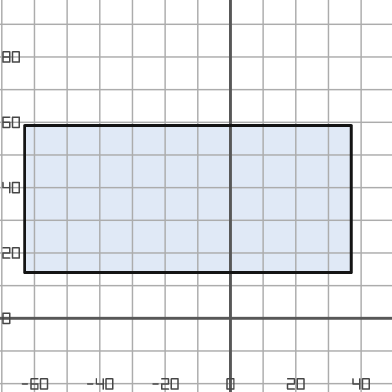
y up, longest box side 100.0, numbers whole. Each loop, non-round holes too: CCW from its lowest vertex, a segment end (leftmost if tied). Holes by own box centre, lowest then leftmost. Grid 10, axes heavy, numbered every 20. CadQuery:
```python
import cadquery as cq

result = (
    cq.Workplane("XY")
    .moveTo(-63.0, 14.0)
    .lineTo(37.0, 14.0)
    .lineTo(37.0, 59.0)
    .lineTo(-63.0, 59.0)
    .close()
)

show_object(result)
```